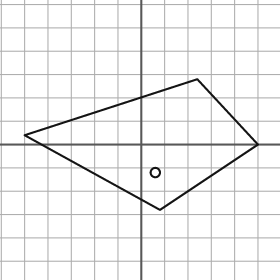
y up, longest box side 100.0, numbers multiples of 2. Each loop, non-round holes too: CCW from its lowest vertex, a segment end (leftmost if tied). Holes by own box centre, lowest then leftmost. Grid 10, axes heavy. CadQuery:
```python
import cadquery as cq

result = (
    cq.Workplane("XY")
    .moveTo(8.0, -28.0)
    .lineTo(50.0, 0.0)
    .lineTo(24.0, 28.0)
    .lineTo(-50.0, 4.0)
    .close()
    .moveTo(6.0, -12.0)
    .circle(2.0)
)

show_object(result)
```